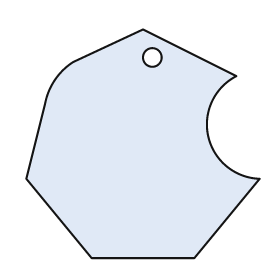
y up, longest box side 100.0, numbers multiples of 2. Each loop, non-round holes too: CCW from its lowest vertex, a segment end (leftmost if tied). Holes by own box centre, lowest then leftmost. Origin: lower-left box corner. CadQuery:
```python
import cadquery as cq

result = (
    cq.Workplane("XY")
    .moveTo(28.0, 0.0)
    .lineTo(72.0, 0.0)
    .lineTo(100.0, 34.0)
    .threePointArc((78.0, 52.0), (90.0, 78.0))
    .lineTo(50.0, 98.0)
    .lineTo(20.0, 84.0)
    .threePointArc((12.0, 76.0), (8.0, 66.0))
    .lineTo(0.0, 34.0)
    .close()
    .moveTo(54.0, 86.0)
    .circle(4.0)
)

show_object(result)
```